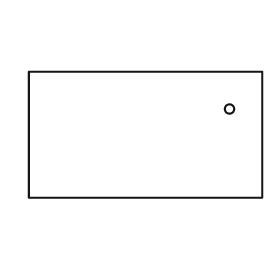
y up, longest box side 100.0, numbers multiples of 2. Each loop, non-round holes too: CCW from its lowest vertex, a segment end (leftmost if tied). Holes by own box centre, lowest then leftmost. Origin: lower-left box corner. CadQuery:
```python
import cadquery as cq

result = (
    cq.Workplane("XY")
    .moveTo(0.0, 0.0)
    .lineTo(100.0, 0.0)
    .lineTo(100.0, 54.0)
    .lineTo(0.0, 54.0)
    .close()
    .moveTo(86.0, 38.0)
    .circle(2.0)
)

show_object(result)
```